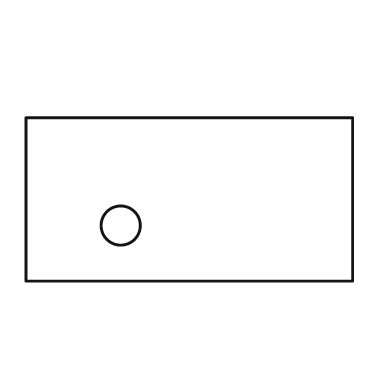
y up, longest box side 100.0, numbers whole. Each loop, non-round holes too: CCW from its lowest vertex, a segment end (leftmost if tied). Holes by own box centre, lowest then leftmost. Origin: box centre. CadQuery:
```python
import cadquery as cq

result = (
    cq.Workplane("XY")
    .moveTo(-50.0, -25.0)
    .lineTo(50.0, -25.0)
    .lineTo(50.0, 25.0)
    .lineTo(-50.0, 25.0)
    .close()
    .moveTo(-21.0, -8.0)
    .circle(6.0)
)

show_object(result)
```